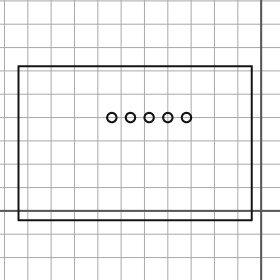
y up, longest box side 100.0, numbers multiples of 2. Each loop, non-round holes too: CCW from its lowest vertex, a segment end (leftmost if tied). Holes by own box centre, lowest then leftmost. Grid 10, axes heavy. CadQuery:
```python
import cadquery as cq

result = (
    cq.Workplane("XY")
    .moveTo(-104.0, -4.0)
    .lineTo(-4.0, -4.0)
    .lineTo(-4.0, 62.0)
    .lineTo(-104.0, 62.0)
    .close()
    .moveTo(-64.0, 40.0)
    .circle(2.0)
    .moveTo(-56.0, 40.0)
    .circle(2.0)
    .moveTo(-48.0, 40.0)
    .circle(2.0)
    .moveTo(-40.0, 40.0)
    .circle(2.0)
    .moveTo(-32.0, 40.0)
    .circle(2.0)
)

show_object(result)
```